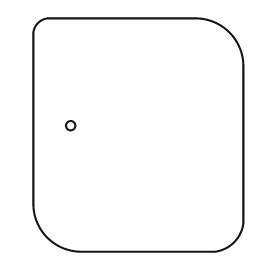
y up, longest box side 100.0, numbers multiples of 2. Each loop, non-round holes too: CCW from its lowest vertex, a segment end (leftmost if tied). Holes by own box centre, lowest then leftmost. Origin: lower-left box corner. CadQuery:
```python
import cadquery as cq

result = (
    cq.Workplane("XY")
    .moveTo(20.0, 0.0)
    .lineTo(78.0, 0.0)
    .threePointArc((86.0, 4.0), (90.0, 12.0))
    .lineTo(90.0, 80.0)
    .threePointArc((84.0, 94.0), (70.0, 100.0))
    .lineTo(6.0, 100.0)
    .threePointArc((2.0, 98.0), (0.0, 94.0))
    .lineTo(0.0, 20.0)
    .threePointArc((6.0, 6.0), (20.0, 0.0))
    .close()
    .moveTo(16.0, 54.0)
    .circle(2.0)
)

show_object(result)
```